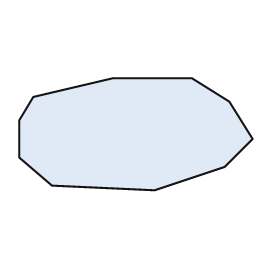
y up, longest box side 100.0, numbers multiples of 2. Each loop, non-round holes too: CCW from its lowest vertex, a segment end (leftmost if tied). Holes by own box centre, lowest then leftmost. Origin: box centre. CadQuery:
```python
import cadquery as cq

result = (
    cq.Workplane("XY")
    .moveTo(8.0, -24.0)
    .lineTo(38.0, -14.0)
    .lineTo(50.0, -2.0)
    .lineTo(40.0, 14.0)
    .lineTo(24.0, 24.0)
    .lineTo(-10.0, 24.0)
    .lineTo(-44.0, 16.0)
    .lineTo(-50.0, 6.0)
    .lineTo(-50.0, -10.0)
    .lineTo(-36.0, -22.0)
    .close()
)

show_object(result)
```